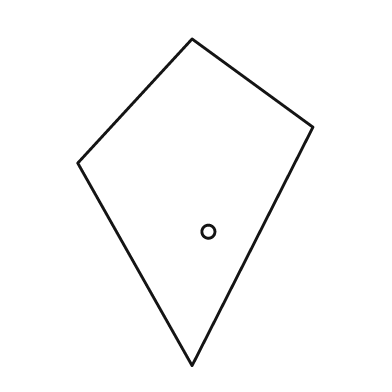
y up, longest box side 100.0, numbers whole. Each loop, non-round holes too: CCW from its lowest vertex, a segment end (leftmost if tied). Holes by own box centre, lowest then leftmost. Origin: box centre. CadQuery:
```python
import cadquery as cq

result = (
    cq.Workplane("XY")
    .moveTo(-1.0, -50.0)
    .lineTo(36.0, 23.0)
    .lineTo(-1.0, 50.0)
    .lineTo(-36.0, 12.0)
    .close()
    .moveTo(4.0, -9.0)
    .circle(2.0)
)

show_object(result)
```